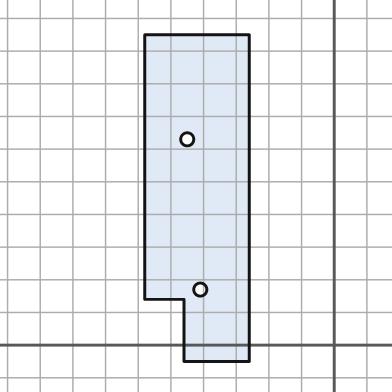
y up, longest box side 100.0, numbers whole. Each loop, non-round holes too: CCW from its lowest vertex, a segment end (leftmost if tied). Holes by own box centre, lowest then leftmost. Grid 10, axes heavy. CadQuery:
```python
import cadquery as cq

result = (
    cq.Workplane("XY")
    .moveTo(-46.0, -5.0)
    .lineTo(-26.0, -5.0)
    .lineTo(-26.0, 95.0)
    .lineTo(-58.0, 95.0)
    .lineTo(-58.0, 14.0)
    .lineTo(-46.0, 14.0)
    .close()
    .moveTo(-41.0, 17.0)
    .circle(2.0)
    .moveTo(-45.0, 63.0)
    .circle(2.0)
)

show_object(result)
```